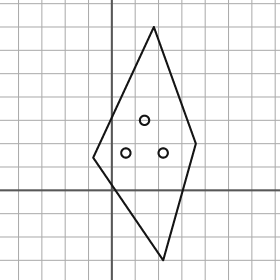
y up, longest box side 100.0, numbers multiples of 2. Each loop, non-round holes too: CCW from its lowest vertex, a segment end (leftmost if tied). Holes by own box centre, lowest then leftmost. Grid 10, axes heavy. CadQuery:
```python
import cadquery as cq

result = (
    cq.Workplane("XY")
    .moveTo(22.0, -30.0)
    .lineTo(36.0, 20.0)
    .lineTo(18.0, 70.0)
    .lineTo(-8.0, 14.0)
    .close()
    .moveTo(6.0, 16.0)
    .circle(2.0)
    .moveTo(22.0, 16.0)
    .circle(2.0)
    .moveTo(14.0, 30.0)
    .circle(2.0)
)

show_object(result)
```